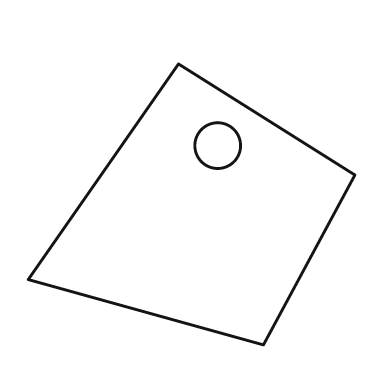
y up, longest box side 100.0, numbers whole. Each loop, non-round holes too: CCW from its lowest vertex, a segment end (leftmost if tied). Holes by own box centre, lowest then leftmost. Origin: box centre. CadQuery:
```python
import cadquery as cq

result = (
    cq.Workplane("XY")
    .moveTo(22.0, -43.0)
    .lineTo(50.0, 9.0)
    .lineTo(-4.0, 43.0)
    .lineTo(-50.0, -23.0)
    .close()
    .moveTo(8.0, 18.0)
    .circle(7.0)
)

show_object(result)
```